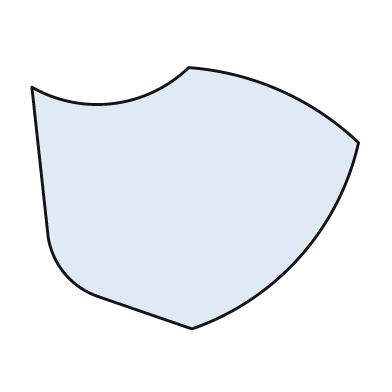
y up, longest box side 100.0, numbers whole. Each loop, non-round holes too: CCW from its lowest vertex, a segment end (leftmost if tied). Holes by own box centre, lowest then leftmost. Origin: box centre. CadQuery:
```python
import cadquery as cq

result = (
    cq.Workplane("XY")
    .moveTo(-1.0, -40.0)
    .threePointArc((32.0, -18.0), (50.0, 17.0))
    .threePointArc((26.0, 33.0), (-2.0, 40.0))
    .threePointArc((-25.0, 29.0), (-50.0, 34.0))
    .lineTo(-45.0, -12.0)
    .threePointArc((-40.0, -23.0), (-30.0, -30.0))
    .close()
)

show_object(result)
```